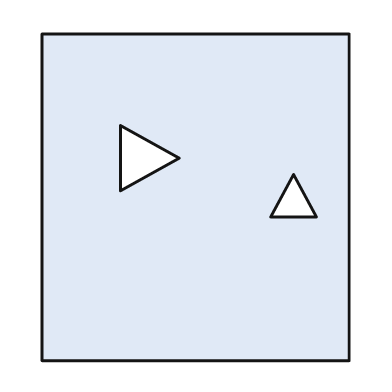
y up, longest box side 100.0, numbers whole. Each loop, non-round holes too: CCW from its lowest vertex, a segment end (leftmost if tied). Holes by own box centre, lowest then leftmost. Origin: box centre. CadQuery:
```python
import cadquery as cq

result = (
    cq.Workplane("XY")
    .moveTo(-47.0, -50.0)
    .lineTo(47.0, -50.0)
    .lineTo(47.0, 50.0)
    .lineTo(-47.0, 50.0)
    .close()
    .moveTo(23.0, -6.0)
    .lineTo(37.0, -6.0)
    .lineTo(30.0, 7.0)
    .close()
    .moveTo(-23.0, 2.0)
    .lineTo(-5.0, 12.0)
    .lineTo(-23.0, 22.0)
    .close()
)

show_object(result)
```